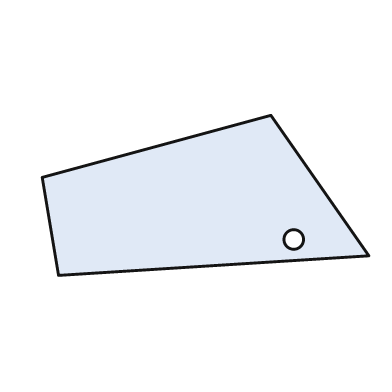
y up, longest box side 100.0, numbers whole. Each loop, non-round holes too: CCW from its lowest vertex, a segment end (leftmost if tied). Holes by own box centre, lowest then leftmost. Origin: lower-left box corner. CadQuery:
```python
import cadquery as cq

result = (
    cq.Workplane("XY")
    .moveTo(5.0, 0.0)
    .lineTo(100.0, 6.0)
    .lineTo(70.0, 49.0)
    .lineTo(0.0, 30.0)
    .close()
    .moveTo(77.0, 11.0)
    .circle(3.0)
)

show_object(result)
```